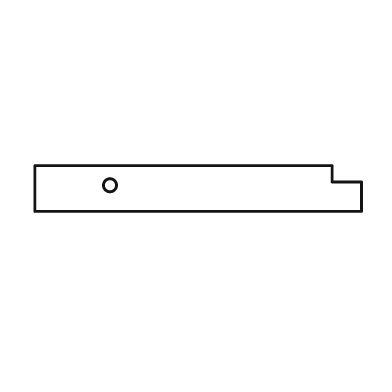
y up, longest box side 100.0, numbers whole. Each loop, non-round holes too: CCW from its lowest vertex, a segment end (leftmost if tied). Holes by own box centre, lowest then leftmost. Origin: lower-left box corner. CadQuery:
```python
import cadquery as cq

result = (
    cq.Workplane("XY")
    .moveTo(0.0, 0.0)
    .lineTo(100.0, 0.0)
    .lineTo(100.0, 9.0)
    .lineTo(91.0, 9.0)
    .lineTo(91.0, 14.0)
    .lineTo(0.0, 14.0)
    .close()
    .moveTo(23.0, 8.0)
    .circle(2.0)
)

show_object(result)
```